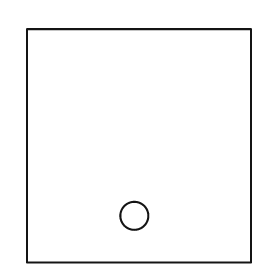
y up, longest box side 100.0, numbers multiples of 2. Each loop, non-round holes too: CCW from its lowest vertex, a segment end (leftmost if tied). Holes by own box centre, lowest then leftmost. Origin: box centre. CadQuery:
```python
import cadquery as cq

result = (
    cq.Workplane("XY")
    .moveTo(-48.0, -50.0)
    .lineTo(48.0, -50.0)
    .lineTo(48.0, 50.0)
    .lineTo(-48.0, 50.0)
    .close()
    .moveTo(-2.0, -30.0)
    .circle(6.0)
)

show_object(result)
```